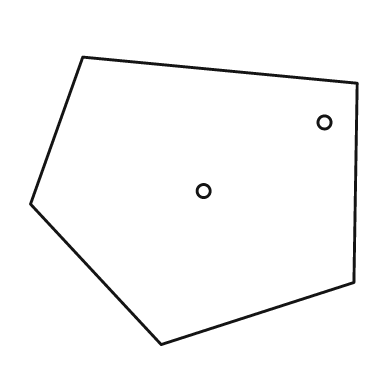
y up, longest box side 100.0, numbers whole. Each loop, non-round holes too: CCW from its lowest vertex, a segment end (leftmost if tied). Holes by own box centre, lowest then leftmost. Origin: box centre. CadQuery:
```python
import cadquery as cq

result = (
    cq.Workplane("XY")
    .moveTo(-10.0, -44.0)
    .lineTo(49.0, -25.0)
    .lineTo(50.0, 36.0)
    .lineTo(-34.0, 44.0)
    .lineTo(-50.0, -1.0)
    .close()
    .moveTo(3.0, 3.0)
    .circle(2.0)
    .moveTo(40.0, 24.0)
    .circle(2.0)
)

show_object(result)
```